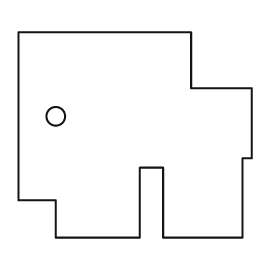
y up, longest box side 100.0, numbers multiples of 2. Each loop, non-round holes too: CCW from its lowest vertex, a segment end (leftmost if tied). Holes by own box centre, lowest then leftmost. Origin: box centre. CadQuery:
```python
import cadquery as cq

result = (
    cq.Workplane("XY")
    .moveTo(-34.0, -44.0)
    .lineTo(2.0, -44.0)
    .lineTo(2.0, -14.0)
    .lineTo(12.0, -14.0)
    .lineTo(12.0, -44.0)
    .lineTo(46.0, -44.0)
    .lineTo(46.0, -10.0)
    .lineTo(50.0, -10.0)
    .lineTo(50.0, 20.0)
    .lineTo(24.0, 20.0)
    .lineTo(24.0, 44.0)
    .lineTo(-50.0, 44.0)
    .lineTo(-50.0, -28.0)
    .lineTo(-34.0, -28.0)
    .close()
    .moveTo(-34.0, 8.0)
    .circle(4.0)
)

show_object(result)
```